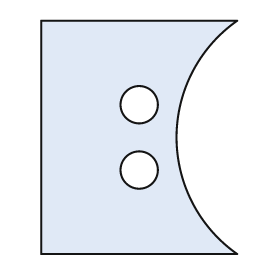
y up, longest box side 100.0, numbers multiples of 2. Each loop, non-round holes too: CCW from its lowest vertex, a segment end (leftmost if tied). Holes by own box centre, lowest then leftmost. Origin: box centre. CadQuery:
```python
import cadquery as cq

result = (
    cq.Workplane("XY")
    .moveTo(-42.0, -50.0)
    .lineTo(42.0, -50.0)
    .threePointArc((16.0, 0.0), (42.0, 50.0))
    .lineTo(-42.0, 50.0)
    .close()
    .moveTo(0.0, -14.0)
    .circle(8.0)
    .moveTo(0.0, 14.0)
    .circle(8.0)
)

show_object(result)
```